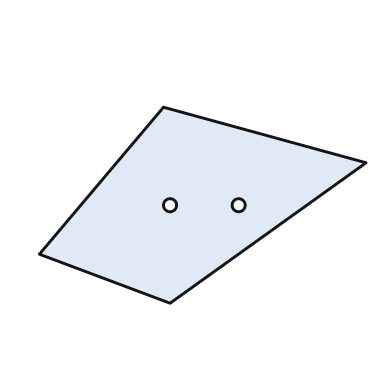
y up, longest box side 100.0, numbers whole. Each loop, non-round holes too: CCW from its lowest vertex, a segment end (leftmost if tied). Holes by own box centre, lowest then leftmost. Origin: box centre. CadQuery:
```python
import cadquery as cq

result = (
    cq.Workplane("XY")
    .moveTo(-10.0, -30.0)
    .lineTo(50.0, 13.0)
    .lineTo(-12.0, 30.0)
    .lineTo(-50.0, -15.0)
    .close()
    .moveTo(-10.0, 0.0)
    .circle(2.0)
    .moveTo(11.0, 0.0)
    .circle(2.0)
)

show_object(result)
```